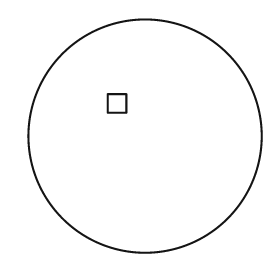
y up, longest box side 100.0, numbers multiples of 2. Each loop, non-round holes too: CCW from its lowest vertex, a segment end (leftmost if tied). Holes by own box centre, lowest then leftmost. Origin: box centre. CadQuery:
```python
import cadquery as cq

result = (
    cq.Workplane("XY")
    .moveTo(0.0, 0.0)
    .circle(50.0)
    .moveTo(-16.0, 10.0)
    .lineTo(-8.0, 10.0)
    .lineTo(-8.0, 18.0)
    .lineTo(-16.0, 18.0)
    .close()
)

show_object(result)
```